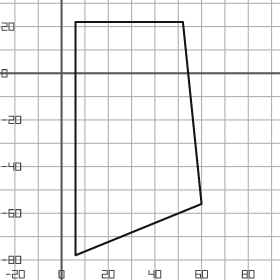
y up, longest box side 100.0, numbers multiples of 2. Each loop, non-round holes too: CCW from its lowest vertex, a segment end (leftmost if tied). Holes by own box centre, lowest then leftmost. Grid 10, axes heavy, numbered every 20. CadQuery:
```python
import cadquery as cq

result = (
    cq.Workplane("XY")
    .moveTo(6.0, -78.0)
    .lineTo(60.0, -56.0)
    .lineTo(52.0, 22.0)
    .lineTo(6.0, 22.0)
    .close()
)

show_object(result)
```